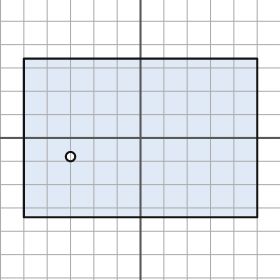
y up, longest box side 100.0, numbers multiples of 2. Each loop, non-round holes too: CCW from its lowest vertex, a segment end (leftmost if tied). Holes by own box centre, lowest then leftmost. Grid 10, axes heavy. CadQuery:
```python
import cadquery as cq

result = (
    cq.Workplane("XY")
    .moveTo(-50.0, -34.0)
    .lineTo(50.0, -34.0)
    .lineTo(50.0, 34.0)
    .lineTo(-50.0, 34.0)
    .close()
    .moveTo(-30.0, -8.0)
    .circle(2.0)
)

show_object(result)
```